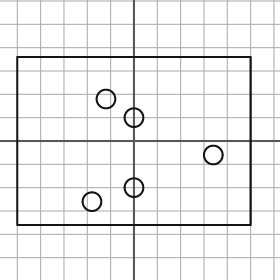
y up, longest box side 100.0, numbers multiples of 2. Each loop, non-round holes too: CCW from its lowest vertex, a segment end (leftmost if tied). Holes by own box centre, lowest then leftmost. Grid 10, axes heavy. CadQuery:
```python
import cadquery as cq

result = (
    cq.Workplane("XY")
    .moveTo(-50.0, -36.0)
    .lineTo(50.0, -36.0)
    .lineTo(50.0, 36.0)
    .lineTo(-50.0, 36.0)
    .close()
    .moveTo(-18.0, -26.0)
    .circle(4.0)
    .moveTo(0.0, -20.0)
    .circle(4.0)
    .moveTo(34.0, -6.0)
    .circle(4.0)
    .moveTo(0.0, 10.0)
    .circle(4.0)
    .moveTo(-12.0, 18.0)
    .circle(4.0)
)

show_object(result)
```